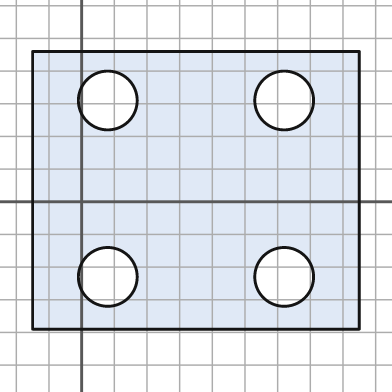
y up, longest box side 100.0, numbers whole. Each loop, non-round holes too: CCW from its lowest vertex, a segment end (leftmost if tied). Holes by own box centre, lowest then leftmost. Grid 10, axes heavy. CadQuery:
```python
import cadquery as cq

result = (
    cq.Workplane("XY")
    .moveTo(-15.0, -39.0)
    .lineTo(85.0, -39.0)
    .lineTo(85.0, 46.0)
    .lineTo(-15.0, 46.0)
    .close()
    .moveTo(8.0, -23.0)
    .circle(9.0)
    .moveTo(62.0, -23.0)
    .circle(9.0)
    .moveTo(8.0, 31.0)
    .circle(9.0)
    .moveTo(62.0, 31.0)
    .circle(9.0)
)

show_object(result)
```